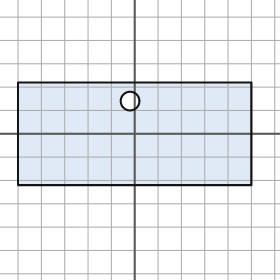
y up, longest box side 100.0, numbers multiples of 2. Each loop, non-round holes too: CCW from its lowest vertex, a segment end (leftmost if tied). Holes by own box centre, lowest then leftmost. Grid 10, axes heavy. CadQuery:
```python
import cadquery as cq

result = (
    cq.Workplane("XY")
    .moveTo(-50.0, -22.0)
    .lineTo(50.0, -22.0)
    .lineTo(50.0, 22.0)
    .lineTo(-50.0, 22.0)
    .close()
    .moveTo(-2.0, 14.0)
    .circle(4.0)
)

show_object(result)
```